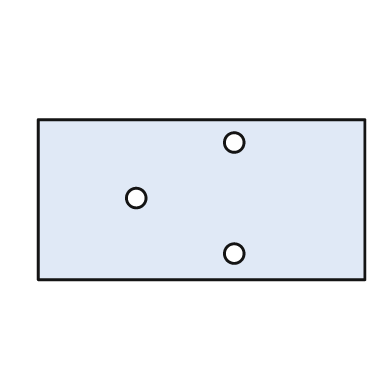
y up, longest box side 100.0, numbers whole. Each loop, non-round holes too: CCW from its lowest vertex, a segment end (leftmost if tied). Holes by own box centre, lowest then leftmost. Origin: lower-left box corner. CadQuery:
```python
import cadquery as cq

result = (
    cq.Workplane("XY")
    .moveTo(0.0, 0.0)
    .lineTo(100.0, 0.0)
    .lineTo(100.0, 49.0)
    .lineTo(0.0, 49.0)
    .close()
    .moveTo(60.0, 8.0)
    .circle(3.0)
    .moveTo(30.0, 25.0)
    .circle(3.0)
    .moveTo(60.0, 42.0)
    .circle(3.0)
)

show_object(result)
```